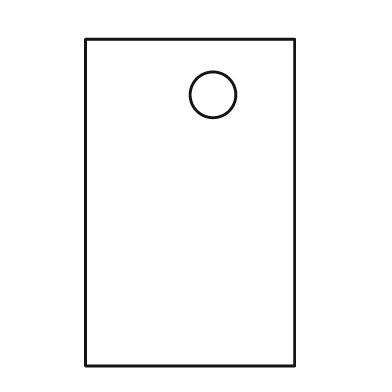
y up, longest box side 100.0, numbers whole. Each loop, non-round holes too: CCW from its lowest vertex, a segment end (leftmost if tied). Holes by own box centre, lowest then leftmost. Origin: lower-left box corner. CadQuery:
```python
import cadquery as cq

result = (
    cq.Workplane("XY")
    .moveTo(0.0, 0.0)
    .lineTo(64.0, 0.0)
    .lineTo(64.0, 100.0)
    .lineTo(0.0, 100.0)
    .close()
    .moveTo(39.0, 83.0)
    .circle(7.0)
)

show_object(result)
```